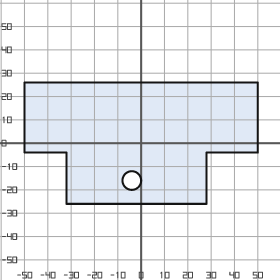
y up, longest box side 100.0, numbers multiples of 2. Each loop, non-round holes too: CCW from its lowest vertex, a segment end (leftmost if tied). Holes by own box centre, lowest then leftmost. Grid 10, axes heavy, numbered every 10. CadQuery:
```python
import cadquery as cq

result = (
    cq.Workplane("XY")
    .moveTo(-32.0, -26.0)
    .lineTo(28.0, -26.0)
    .lineTo(28.0, -4.0)
    .lineTo(50.0, -4.0)
    .lineTo(50.0, 26.0)
    .lineTo(-50.0, 26.0)
    .lineTo(-50.0, -4.0)
    .lineTo(-32.0, -4.0)
    .close()
    .moveTo(-4.0, -16.0)
    .circle(4.0)
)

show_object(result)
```